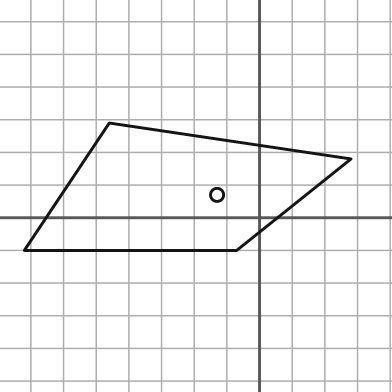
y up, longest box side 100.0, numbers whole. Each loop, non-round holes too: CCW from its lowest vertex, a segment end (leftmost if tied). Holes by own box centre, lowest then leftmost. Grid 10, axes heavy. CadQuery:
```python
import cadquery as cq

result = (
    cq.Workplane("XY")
    .moveTo(-72.0, -10.0)
    .lineTo(-7.0, -10.0)
    .lineTo(28.0, 18.0)
    .lineTo(-46.0, 29.0)
    .close()
    .moveTo(-13.0, 7.0)
    .circle(2.0)
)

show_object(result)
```